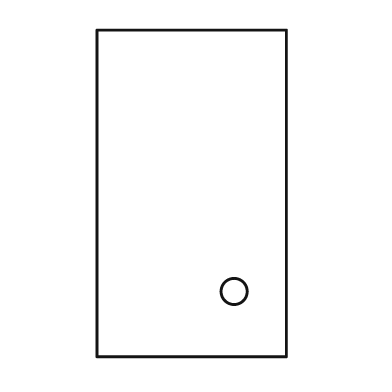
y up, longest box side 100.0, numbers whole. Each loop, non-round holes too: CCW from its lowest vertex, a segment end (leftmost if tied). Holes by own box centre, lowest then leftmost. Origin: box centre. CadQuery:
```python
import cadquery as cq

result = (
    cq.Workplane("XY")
    .moveTo(-29.0, -50.0)
    .lineTo(29.0, -50.0)
    .lineTo(29.0, 50.0)
    .lineTo(-29.0, 50.0)
    .close()
    .moveTo(13.0, -30.0)
    .circle(4.0)
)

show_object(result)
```